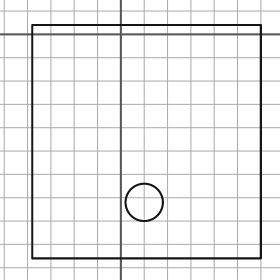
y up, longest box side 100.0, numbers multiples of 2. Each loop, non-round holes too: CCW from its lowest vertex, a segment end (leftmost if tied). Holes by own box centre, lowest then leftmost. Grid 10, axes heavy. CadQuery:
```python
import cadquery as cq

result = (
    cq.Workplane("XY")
    .moveTo(-38.0, -96.0)
    .lineTo(60.0, -96.0)
    .lineTo(60.0, 4.0)
    .lineTo(-38.0, 4.0)
    .close()
    .moveTo(10.0, -72.0)
    .circle(8.0)
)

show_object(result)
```